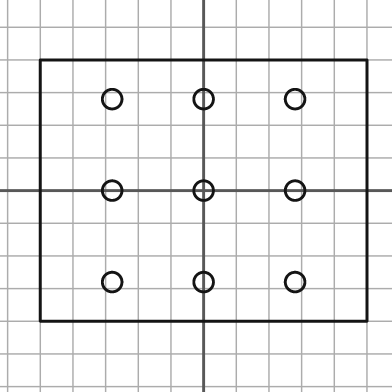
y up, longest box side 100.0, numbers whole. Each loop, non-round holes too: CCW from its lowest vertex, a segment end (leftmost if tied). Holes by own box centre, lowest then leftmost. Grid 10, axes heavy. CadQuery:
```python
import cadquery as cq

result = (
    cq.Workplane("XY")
    .moveTo(-50.0, -40.0)
    .lineTo(50.0, -40.0)
    .lineTo(50.0, 40.0)
    .lineTo(-50.0, 40.0)
    .close()
    .moveTo(-28.0, -28.0)
    .circle(3.0)
    .moveTo(0.0, -28.0)
    .circle(3.0)
    .moveTo(28.0, -28.0)
    .circle(3.0)
    .moveTo(-28.0, 0.0)
    .circle(3.0)
    .moveTo(0.0, 0.0)
    .circle(3.0)
    .moveTo(28.0, 0.0)
    .circle(3.0)
    .moveTo(-28.0, 28.0)
    .circle(3.0)
    .moveTo(0.0, 28.0)
    .circle(3.0)
    .moveTo(28.0, 28.0)
    .circle(3.0)
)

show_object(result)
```